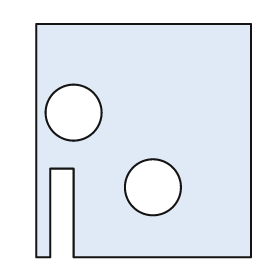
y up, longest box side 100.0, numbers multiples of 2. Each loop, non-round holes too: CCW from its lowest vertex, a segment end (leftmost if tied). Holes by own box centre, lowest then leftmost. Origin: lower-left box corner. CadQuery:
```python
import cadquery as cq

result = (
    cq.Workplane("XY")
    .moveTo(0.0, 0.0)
    .lineTo(6.0, 0.0)
    .lineTo(6.0, 38.0)
    .lineTo(16.0, 38.0)
    .lineTo(16.0, 0.0)
    .lineTo(92.0, 0.0)
    .lineTo(92.0, 100.0)
    .lineTo(0.0, 100.0)
    .close()
    .moveTo(50.0, 30.0)
    .circle(12.0)
    .moveTo(16.0, 62.0)
    .circle(12.0)
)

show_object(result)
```